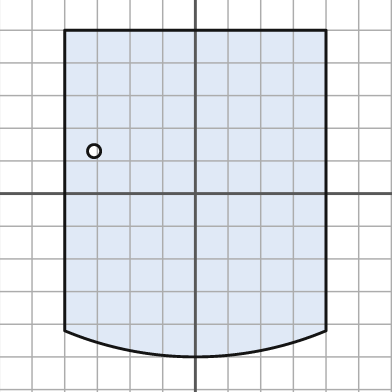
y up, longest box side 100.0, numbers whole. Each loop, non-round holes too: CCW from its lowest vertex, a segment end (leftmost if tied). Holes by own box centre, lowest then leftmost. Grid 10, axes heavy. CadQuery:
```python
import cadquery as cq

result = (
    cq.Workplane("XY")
    .moveTo(-40.0, -42.0)
    .threePointArc((0.0, -50.0), (40.0, -42.0))
    .lineTo(40.0, 50.0)
    .lineTo(-40.0, 50.0)
    .close()
    .moveTo(-31.0, 13.0)
    .circle(2.0)
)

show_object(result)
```